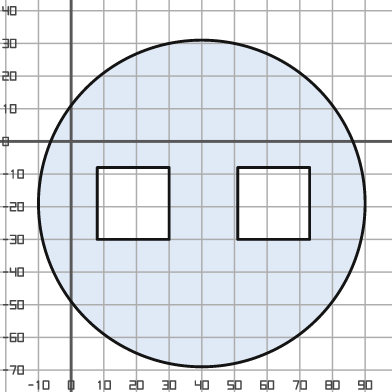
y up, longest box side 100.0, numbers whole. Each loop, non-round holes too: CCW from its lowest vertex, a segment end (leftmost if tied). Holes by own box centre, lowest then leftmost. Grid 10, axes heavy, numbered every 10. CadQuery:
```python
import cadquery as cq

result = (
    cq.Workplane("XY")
    .moveTo(40.0, -19.0)
    .circle(50.0)
    .moveTo(8.0, -30.0)
    .lineTo(30.0, -30.0)
    .lineTo(30.0, -8.0)
    .lineTo(8.0, -8.0)
    .close()
    .moveTo(51.0, -30.0)
    .lineTo(73.0, -30.0)
    .lineTo(73.0, -8.0)
    .lineTo(51.0, -8.0)
    .close()
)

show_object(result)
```